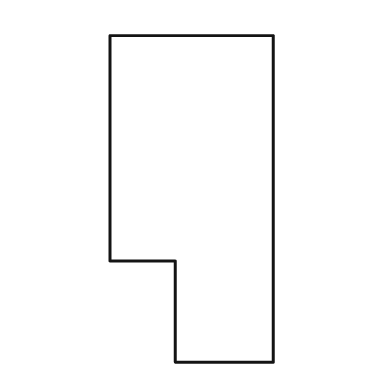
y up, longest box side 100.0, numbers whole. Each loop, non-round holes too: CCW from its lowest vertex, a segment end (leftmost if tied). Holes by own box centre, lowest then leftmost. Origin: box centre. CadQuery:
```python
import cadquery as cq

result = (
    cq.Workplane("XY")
    .moveTo(-5.0, -50.0)
    .lineTo(25.0, -50.0)
    .lineTo(25.0, 50.0)
    .lineTo(-25.0, 50.0)
    .lineTo(-25.0, -19.0)
    .lineTo(-5.0, -19.0)
    .close()
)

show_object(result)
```